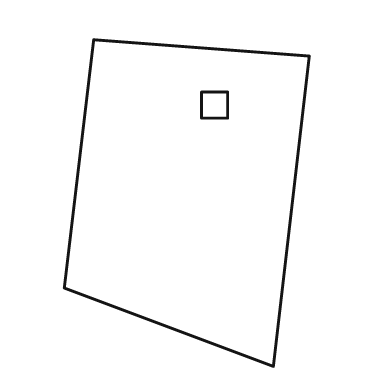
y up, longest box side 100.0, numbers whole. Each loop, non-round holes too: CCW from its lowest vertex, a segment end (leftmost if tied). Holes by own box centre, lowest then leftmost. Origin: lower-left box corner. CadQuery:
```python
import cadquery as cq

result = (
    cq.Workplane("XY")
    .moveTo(64.0, 0.0)
    .lineTo(75.0, 95.0)
    .lineTo(9.0, 100.0)
    .lineTo(0.0, 24.0)
    .close()
    .moveTo(42.0, 76.0)
    .lineTo(50.0, 76.0)
    .lineTo(50.0, 84.0)
    .lineTo(42.0, 84.0)
    .close()
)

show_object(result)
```